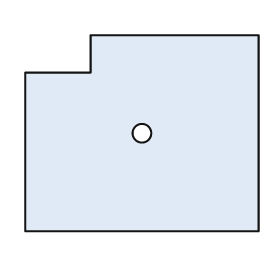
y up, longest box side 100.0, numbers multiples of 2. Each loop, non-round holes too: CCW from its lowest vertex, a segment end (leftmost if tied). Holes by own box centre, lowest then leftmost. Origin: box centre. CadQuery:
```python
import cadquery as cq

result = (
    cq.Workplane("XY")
    .moveTo(-50.0, -42.0)
    .lineTo(50.0, -42.0)
    .lineTo(50.0, 42.0)
    .lineTo(-22.0, 42.0)
    .lineTo(-22.0, 26.0)
    .lineTo(-50.0, 26.0)
    .close()
    .moveTo(0.0, 0.0)
    .circle(4.0)
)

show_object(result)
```